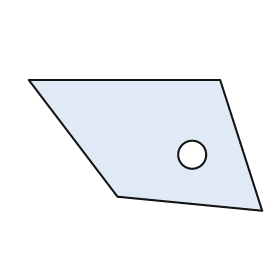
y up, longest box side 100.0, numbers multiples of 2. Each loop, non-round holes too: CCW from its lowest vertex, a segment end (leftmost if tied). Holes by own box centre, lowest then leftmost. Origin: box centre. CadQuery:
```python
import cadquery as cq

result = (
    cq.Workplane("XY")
    .moveTo(50.0, -28.0)
    .lineTo(32.0, 28.0)
    .lineTo(-50.0, 28.0)
    .lineTo(-12.0, -22.0)
    .close()
    .moveTo(20.0, -4.0)
    .circle(6.0)
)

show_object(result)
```